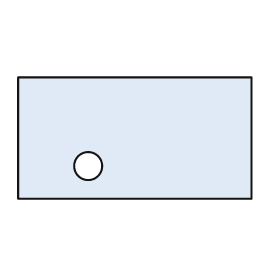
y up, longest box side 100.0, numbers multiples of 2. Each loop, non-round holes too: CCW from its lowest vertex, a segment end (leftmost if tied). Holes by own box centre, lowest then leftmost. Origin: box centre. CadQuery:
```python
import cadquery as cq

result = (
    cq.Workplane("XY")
    .moveTo(-50.0, -26.0)
    .lineTo(50.0, -26.0)
    .lineTo(50.0, 26.0)
    .lineTo(-50.0, 26.0)
    .close()
    .moveTo(-20.0, -12.0)
    .circle(6.0)
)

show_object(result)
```